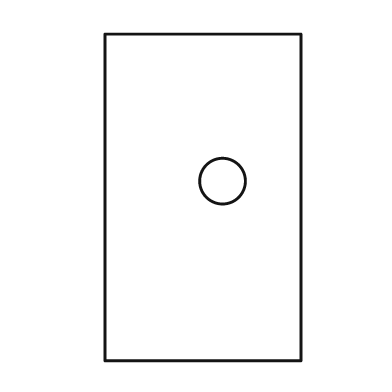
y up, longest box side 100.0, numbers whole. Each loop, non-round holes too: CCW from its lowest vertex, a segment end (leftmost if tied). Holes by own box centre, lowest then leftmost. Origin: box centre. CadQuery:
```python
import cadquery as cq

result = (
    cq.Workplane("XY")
    .moveTo(-30.0, -50.0)
    .lineTo(30.0, -50.0)
    .lineTo(30.0, 50.0)
    .lineTo(-30.0, 50.0)
    .close()
    .moveTo(6.0, 5.0)
    .circle(7.0)
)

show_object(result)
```